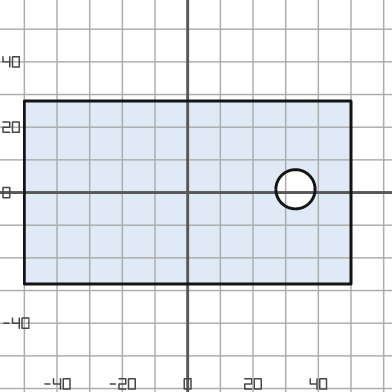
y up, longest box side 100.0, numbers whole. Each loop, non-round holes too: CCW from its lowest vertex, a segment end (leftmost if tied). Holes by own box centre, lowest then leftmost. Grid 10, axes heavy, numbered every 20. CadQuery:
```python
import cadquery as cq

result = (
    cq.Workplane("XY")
    .moveTo(-50.0, -28.0)
    .lineTo(50.0, -28.0)
    .lineTo(50.0, 28.0)
    .lineTo(-50.0, 28.0)
    .close()
    .moveTo(33.0, 1.0)
    .circle(6.0)
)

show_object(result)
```